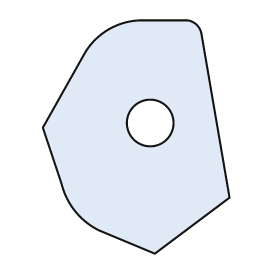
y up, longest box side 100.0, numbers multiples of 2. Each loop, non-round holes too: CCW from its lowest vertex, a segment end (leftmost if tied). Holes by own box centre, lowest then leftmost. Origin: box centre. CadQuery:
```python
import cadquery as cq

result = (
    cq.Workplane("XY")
    .moveTo(8.0, -50.0)
    .lineTo(40.0, -26.0)
    .lineTo(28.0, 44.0)
    .threePointArc((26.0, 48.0), (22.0, 50.0))
    .lineTo(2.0, 50.0)
    .threePointArc((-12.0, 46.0), (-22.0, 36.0))
    .lineTo(-40.0, 4.0)
    .lineTo(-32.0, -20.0)
    .threePointArc((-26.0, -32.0), (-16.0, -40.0))
    .close()
    .moveTo(6.0, 6.0)
    .circle(10.0)
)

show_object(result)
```